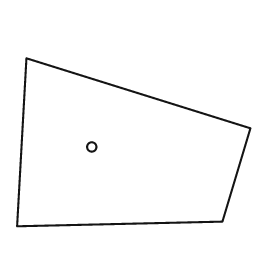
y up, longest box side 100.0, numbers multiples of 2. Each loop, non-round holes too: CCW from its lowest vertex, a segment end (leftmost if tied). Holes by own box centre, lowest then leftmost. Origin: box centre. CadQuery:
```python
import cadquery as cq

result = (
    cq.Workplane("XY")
    .moveTo(-50.0, -36.0)
    .lineTo(38.0, -34.0)
    .lineTo(50.0, 6.0)
    .lineTo(-46.0, 36.0)
    .close()
    .moveTo(-18.0, -2.0)
    .circle(2.0)
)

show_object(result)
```